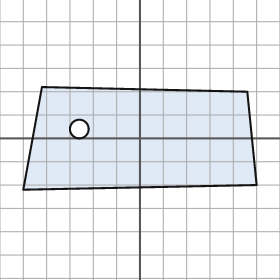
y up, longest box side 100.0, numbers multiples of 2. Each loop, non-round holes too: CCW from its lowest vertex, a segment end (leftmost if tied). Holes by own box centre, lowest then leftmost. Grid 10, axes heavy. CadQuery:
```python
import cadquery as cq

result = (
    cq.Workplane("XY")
    .moveTo(-50.0, -22.0)
    .lineTo(50.0, -20.0)
    .lineTo(46.0, 20.0)
    .lineTo(-42.0, 22.0)
    .close()
    .moveTo(-26.0, 4.0)
    .circle(4.0)
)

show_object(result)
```